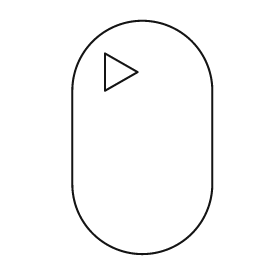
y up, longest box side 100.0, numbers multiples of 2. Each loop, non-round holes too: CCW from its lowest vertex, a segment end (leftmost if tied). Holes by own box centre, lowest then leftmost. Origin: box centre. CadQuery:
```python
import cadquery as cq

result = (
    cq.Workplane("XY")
    .moveTo(-30.0, -20.0)
    .threePointArc((0.0, -50.0), (30.0, -20.0))
    .lineTo(30.0, 20.0)
    .threePointArc((0.0, 50.0), (-30.0, 20.0))
    .close()
    .moveTo(-16.0, 20.0)
    .lineTo(-2.0, 28.0)
    .lineTo(-16.0, 36.0)
    .close()
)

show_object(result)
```